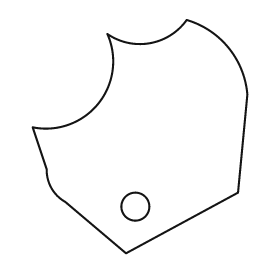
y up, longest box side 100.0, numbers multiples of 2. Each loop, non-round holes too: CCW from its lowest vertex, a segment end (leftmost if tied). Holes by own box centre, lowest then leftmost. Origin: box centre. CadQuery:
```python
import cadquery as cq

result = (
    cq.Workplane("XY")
    .moveTo(-6.0, -50.0)
    .lineTo(42.0, -24.0)
    .lineTo(46.0, 18.0)
    .threePointArc((38.0, 38.0), (20.0, 50.0))
    .threePointArc((4.0, 40.0), (-14.0, 44.0))
    .threePointArc((-18.0, 14.0), (-46.0, 4.0))
    .lineTo(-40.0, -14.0)
    .threePointArc((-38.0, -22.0), (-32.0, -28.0))
    .close()
    .moveTo(-2.0, -30.0)
    .circle(6.0)
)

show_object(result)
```